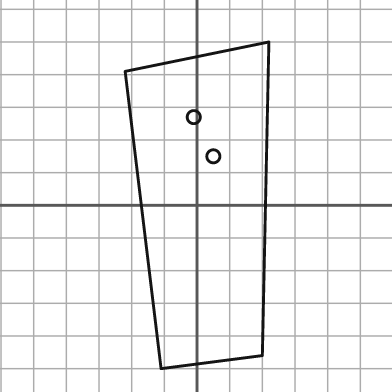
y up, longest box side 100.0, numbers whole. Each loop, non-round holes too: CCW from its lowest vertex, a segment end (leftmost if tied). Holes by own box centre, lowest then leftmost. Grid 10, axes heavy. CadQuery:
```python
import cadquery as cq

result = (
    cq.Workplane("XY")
    .moveTo(-11.0, -50.0)
    .lineTo(20.0, -46.0)
    .lineTo(22.0, 50.0)
    .lineTo(-22.0, 41.0)
    .close()
    .moveTo(5.0, 15.0)
    .circle(2.0)
    .moveTo(-1.0, 27.0)
    .circle(2.0)
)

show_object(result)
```